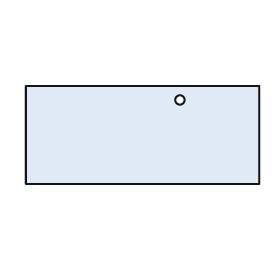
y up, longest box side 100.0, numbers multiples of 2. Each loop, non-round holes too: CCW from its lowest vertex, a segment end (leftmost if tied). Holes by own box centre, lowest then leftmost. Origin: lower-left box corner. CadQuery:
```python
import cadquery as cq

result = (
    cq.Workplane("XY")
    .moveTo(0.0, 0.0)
    .lineTo(100.0, 0.0)
    .lineTo(100.0, 42.0)
    .lineTo(0.0, 42.0)
    .close()
    .moveTo(66.0, 36.0)
    .circle(2.0)
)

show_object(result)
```